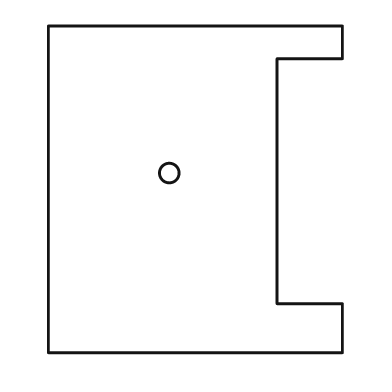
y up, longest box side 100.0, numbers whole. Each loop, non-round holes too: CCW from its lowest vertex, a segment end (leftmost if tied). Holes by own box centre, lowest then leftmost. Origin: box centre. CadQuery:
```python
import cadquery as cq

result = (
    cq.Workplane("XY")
    .moveTo(-45.0, -50.0)
    .lineTo(45.0, -50.0)
    .lineTo(45.0, -35.0)
    .lineTo(25.0, -35.0)
    .lineTo(25.0, 40.0)
    .lineTo(45.0, 40.0)
    .lineTo(45.0, 50.0)
    .lineTo(-45.0, 50.0)
    .close()
    .moveTo(-8.0, 5.0)
    .circle(3.0)
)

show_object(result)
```